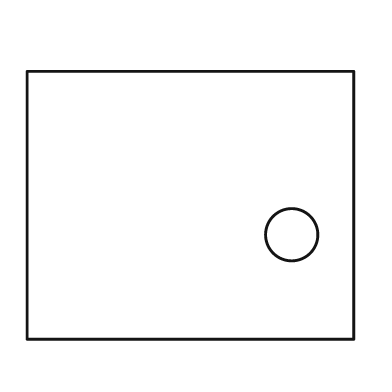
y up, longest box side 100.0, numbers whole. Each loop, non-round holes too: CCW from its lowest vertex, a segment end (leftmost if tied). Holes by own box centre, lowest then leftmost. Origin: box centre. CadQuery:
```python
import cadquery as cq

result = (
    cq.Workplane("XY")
    .moveTo(-50.0, -41.0)
    .lineTo(50.0, -41.0)
    .lineTo(50.0, 41.0)
    .lineTo(-50.0, 41.0)
    .close()
    .moveTo(31.0, -9.0)
    .circle(8.0)
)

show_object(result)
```